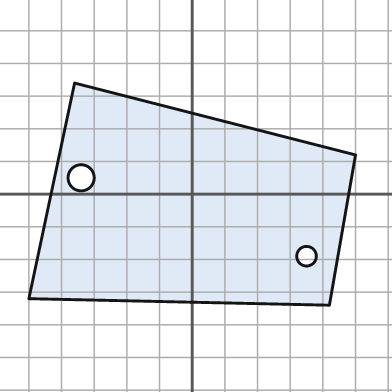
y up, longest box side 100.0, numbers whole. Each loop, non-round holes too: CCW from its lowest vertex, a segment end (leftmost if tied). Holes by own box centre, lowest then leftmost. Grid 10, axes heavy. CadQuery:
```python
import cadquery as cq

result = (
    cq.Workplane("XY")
    .moveTo(42.0, -34.0)
    .lineTo(50.0, 12.0)
    .lineTo(-36.0, 34.0)
    .lineTo(-50.0, -32.0)
    .close()
    .moveTo(35.0, -19.0)
    .circle(3.0)
    .moveTo(-34.0, 5.0)
    .circle(4.0)
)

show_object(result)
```